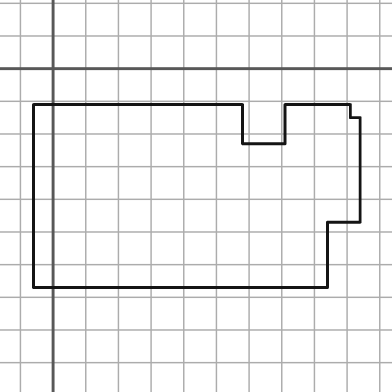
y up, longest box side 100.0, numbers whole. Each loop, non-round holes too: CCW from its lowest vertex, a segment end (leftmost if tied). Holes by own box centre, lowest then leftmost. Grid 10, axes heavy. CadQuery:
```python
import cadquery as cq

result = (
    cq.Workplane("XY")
    .moveTo(-6.0, -67.0)
    .lineTo(84.0, -67.0)
    .lineTo(84.0, -47.0)
    .lineTo(94.0, -47.0)
    .lineTo(94.0, -15.0)
    .lineTo(91.0, -15.0)
    .lineTo(91.0, -11.0)
    .lineTo(71.0, -11.0)
    .lineTo(71.0, -23.0)
    .lineTo(58.0, -23.0)
    .lineTo(58.0, -11.0)
    .lineTo(-6.0, -11.0)
    .close()
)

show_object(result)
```